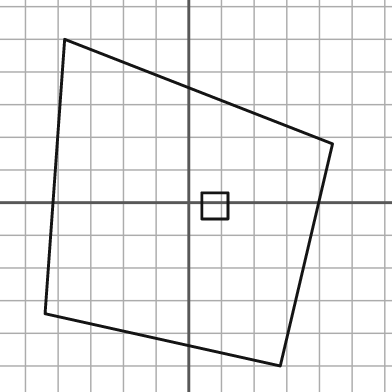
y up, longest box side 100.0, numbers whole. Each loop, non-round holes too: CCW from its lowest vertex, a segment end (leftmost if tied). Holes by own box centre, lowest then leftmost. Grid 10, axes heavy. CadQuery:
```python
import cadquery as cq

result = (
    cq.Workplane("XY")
    .moveTo(28.0, -50.0)
    .lineTo(44.0, 18.0)
    .lineTo(-38.0, 50.0)
    .lineTo(-44.0, -34.0)
    .close()
    .moveTo(4.0, -5.0)
    .lineTo(12.0, -5.0)
    .lineTo(12.0, 3.0)
    .lineTo(4.0, 3.0)
    .close()
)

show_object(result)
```